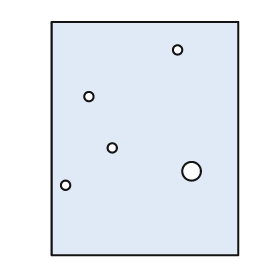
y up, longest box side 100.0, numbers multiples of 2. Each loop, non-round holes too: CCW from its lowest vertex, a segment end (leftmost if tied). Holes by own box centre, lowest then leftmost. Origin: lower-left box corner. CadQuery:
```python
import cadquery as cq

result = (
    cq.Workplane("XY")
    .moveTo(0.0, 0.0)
    .lineTo(80.0, 0.0)
    .lineTo(80.0, 100.0)
    .lineTo(0.0, 100.0)
    .close()
    .moveTo(6.0, 30.0)
    .circle(2.0)
    .moveTo(60.0, 36.0)
    .circle(4.0)
    .moveTo(26.0, 46.0)
    .circle(2.0)
    .moveTo(16.0, 68.0)
    .circle(2.0)
    .moveTo(54.0, 88.0)
    .circle(2.0)
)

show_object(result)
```